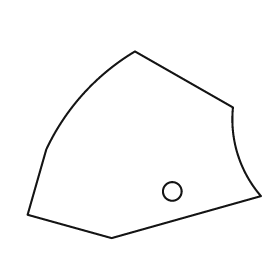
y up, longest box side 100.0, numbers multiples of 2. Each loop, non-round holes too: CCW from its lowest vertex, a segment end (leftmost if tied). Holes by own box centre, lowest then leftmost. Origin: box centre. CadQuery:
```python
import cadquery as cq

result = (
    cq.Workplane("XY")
    .moveTo(-14.0, -40.0)
    .lineTo(50.0, -22.0)
    .threePointArc((40.0, -4.0), (38.0, 16.0))
    .lineTo(-4.0, 40.0)
    .threePointArc((-26.0, 22.0), (-42.0, -2.0))
    .lineTo(-50.0, -30.0)
    .close()
    .moveTo(12.0, -20.0)
    .circle(4.0)
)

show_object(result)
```